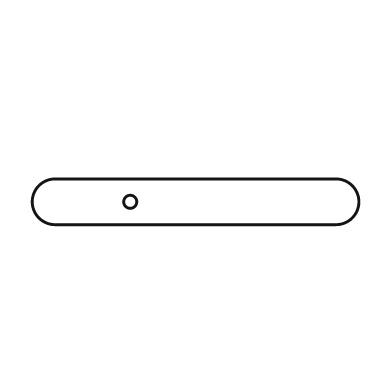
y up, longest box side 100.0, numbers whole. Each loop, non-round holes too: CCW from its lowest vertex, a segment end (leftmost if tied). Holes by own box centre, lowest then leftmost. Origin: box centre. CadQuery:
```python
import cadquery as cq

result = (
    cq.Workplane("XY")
    .moveTo(-43.0, -7.0)
    .lineTo(43.0, -7.0)
    .threePointArc((50.0, 0.0), (43.0, 7.0))
    .lineTo(-43.0, 7.0)
    .threePointArc((-50.0, 0.0), (-43.0, -7.0))
    .close()
    .moveTo(-20.0, 0.0)
    .circle(2.0)
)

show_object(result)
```